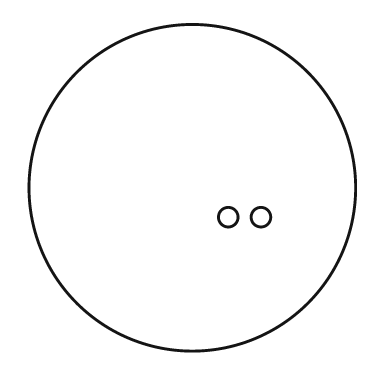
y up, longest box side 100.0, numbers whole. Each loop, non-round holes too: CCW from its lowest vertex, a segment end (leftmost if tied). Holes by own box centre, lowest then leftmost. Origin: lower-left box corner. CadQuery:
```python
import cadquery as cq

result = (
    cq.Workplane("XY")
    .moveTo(50.0, 50.0)
    .circle(50.0)
    .moveTo(61.0, 41.0)
    .circle(3.0)
    .moveTo(71.0, 41.0)
    .circle(3.0)
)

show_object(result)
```